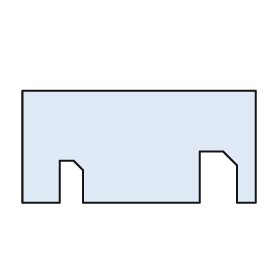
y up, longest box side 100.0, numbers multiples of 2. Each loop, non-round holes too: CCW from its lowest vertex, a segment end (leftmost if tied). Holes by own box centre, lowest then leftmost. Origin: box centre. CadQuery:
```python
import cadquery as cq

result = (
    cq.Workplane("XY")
    .moveTo(-50.0, -24.0)
    .lineTo(-34.0, -24.0)
    .lineTo(-34.0, -6.0)
    .lineTo(-28.0, -6.0)
    .lineTo(-24.0, -10.0)
    .lineTo(-24.0, -24.0)
    .lineTo(26.0, -24.0)
    .lineTo(26.0, -2.0)
    .lineTo(36.0, -2.0)
    .lineTo(42.0, -8.0)
    .lineTo(42.0, -24.0)
    .lineTo(50.0, -24.0)
    .lineTo(50.0, 24.0)
    .lineTo(-50.0, 24.0)
    .close()
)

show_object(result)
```